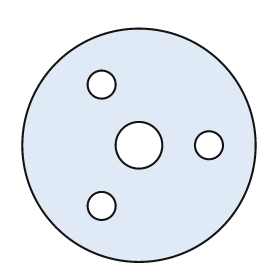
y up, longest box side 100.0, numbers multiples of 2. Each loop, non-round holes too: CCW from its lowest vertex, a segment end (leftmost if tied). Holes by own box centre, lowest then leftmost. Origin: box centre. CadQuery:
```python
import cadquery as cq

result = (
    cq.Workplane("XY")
    .moveTo(0.0, 0.0)
    .circle(50.0)
    .moveTo(-16.0, -26.0)
    .circle(6.0)
    .moveTo(0.0, 0.0)
    .circle(10.0)
    .moveTo(30.0, 0.0)
    .circle(6.0)
    .moveTo(-16.0, 26.0)
    .circle(6.0)
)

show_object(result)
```